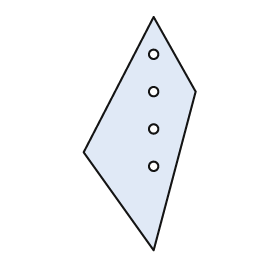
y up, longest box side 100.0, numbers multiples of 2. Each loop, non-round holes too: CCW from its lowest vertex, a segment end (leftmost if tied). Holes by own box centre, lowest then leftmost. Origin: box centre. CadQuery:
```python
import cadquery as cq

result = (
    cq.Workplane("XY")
    .moveTo(6.0, -50.0)
    .lineTo(24.0, 18.0)
    .lineTo(6.0, 50.0)
    .lineTo(-24.0, -8.0)
    .close()
    .moveTo(6.0, -14.0)
    .circle(2.0)
    .moveTo(6.0, 2.0)
    .circle(2.0)
    .moveTo(6.0, 18.0)
    .circle(2.0)
    .moveTo(6.0, 34.0)
    .circle(2.0)
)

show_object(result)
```